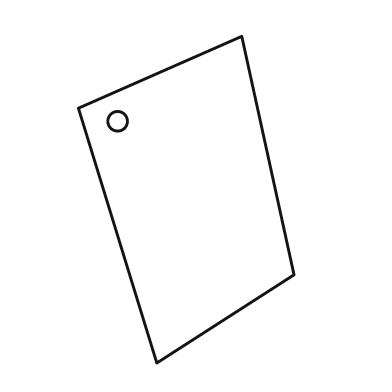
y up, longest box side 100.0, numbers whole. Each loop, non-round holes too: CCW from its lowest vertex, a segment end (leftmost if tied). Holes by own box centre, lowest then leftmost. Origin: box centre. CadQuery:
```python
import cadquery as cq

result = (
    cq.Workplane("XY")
    .moveTo(-9.0, -50.0)
    .lineTo(33.0, -23.0)
    .lineTo(17.0, 50.0)
    .lineTo(-33.0, 28.0)
    .close()
    .moveTo(-21.0, 24.0)
    .circle(3.0)
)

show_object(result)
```